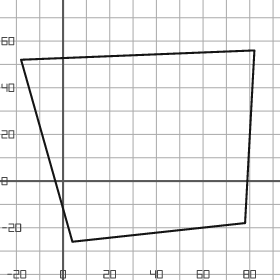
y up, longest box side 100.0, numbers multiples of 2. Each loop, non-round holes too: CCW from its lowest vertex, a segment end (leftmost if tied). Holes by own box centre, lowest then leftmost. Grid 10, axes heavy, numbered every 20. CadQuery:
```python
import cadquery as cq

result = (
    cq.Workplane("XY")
    .moveTo(4.0, -26.0)
    .lineTo(78.0, -18.0)
    .lineTo(82.0, 56.0)
    .lineTo(-18.0, 52.0)
    .close()
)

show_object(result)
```